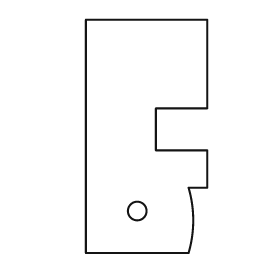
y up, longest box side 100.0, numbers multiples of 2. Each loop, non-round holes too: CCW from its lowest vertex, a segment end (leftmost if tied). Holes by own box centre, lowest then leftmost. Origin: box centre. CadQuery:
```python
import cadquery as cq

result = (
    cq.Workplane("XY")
    .moveTo(-26.0, -50.0)
    .lineTo(18.0, -50.0)
    .threePointArc((20.0, -36.0), (18.0, -22.0))
    .lineTo(26.0, -22.0)
    .lineTo(26.0, -6.0)
    .lineTo(4.0, -6.0)
    .lineTo(4.0, 12.0)
    .lineTo(26.0, 12.0)
    .lineTo(26.0, 50.0)
    .lineTo(-26.0, 50.0)
    .close()
    .moveTo(-4.0, -32.0)
    .circle(4.0)
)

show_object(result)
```